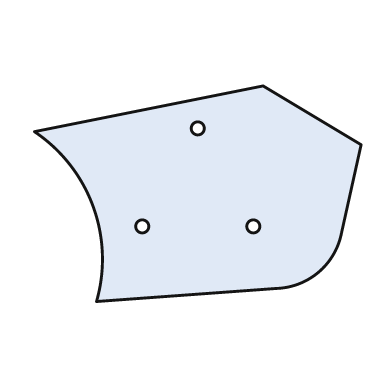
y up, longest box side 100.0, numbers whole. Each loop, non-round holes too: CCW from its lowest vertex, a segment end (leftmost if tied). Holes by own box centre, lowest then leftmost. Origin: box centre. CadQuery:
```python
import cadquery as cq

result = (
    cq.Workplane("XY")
    .moveTo(-31.0, -33.0)
    .lineTo(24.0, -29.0)
    .threePointArc((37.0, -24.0), (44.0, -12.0))
    .lineTo(50.0, 15.0)
    .lineTo(20.0, 33.0)
    .lineTo(-50.0, 19.0)
    .threePointArc((-32.0, -4.0), (-31.0, -33.0))
    .close()
    .moveTo(-17.0, -10.0)
    .circle(2.0)
    .moveTo(17.0, -10.0)
    .circle(2.0)
    .moveTo(0.0, 20.0)
    .circle(2.0)
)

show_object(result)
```